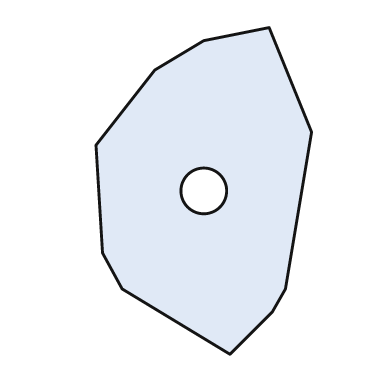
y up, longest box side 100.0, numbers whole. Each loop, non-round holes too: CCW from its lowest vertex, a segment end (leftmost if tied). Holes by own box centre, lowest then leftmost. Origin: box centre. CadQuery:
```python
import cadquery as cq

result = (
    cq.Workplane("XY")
    .moveTo(8.0, -50.0)
    .lineTo(21.0, -37.0)
    .lineTo(25.0, -30.0)
    .lineTo(33.0, 18.0)
    .lineTo(20.0, 50.0)
    .lineTo(0.0, 46.0)
    .lineTo(-15.0, 37.0)
    .lineTo(-33.0, 14.0)
    .lineTo(-31.0, -19.0)
    .lineTo(-25.0, -30.0)
    .close()
    .moveTo(0.0, 0.0)
    .circle(7.0)
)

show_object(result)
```